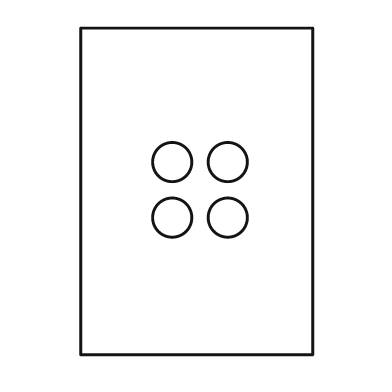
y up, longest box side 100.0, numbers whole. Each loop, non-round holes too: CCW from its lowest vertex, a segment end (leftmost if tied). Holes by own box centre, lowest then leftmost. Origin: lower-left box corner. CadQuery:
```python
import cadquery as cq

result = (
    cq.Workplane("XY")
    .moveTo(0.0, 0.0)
    .lineTo(71.0, 0.0)
    .lineTo(71.0, 100.0)
    .lineTo(0.0, 100.0)
    .close()
    .moveTo(28.0, 42.0)
    .circle(6.0)
    .moveTo(45.0, 42.0)
    .circle(6.0)
    .moveTo(28.0, 59.0)
    .circle(6.0)
    .moveTo(45.0, 59.0)
    .circle(6.0)
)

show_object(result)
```